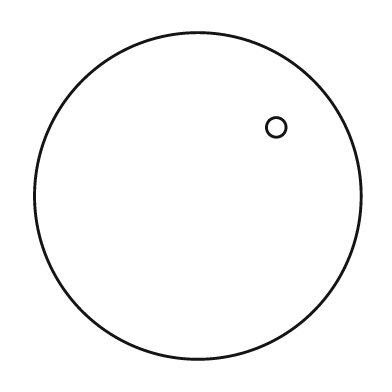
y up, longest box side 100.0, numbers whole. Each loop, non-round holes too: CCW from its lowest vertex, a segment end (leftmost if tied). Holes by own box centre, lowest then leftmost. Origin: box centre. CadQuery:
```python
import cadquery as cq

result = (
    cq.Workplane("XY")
    .moveTo(0.0, 0.0)
    .circle(50.0)
    .moveTo(24.0, 21.0)
    .circle(3.0)
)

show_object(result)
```